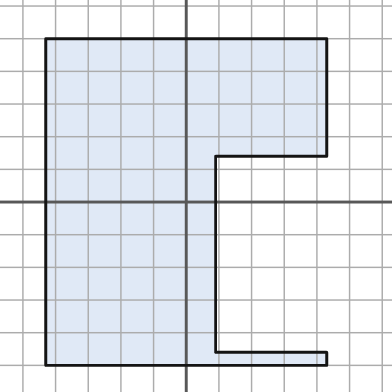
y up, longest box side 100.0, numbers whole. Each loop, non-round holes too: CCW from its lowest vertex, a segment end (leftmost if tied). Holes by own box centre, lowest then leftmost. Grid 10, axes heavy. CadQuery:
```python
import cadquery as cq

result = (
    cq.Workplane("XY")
    .moveTo(-43.0, -50.0)
    .lineTo(43.0, -50.0)
    .lineTo(43.0, -46.0)
    .lineTo(9.0, -46.0)
    .lineTo(9.0, 14.0)
    .lineTo(43.0, 14.0)
    .lineTo(43.0, 50.0)
    .lineTo(-43.0, 50.0)
    .close()
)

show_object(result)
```